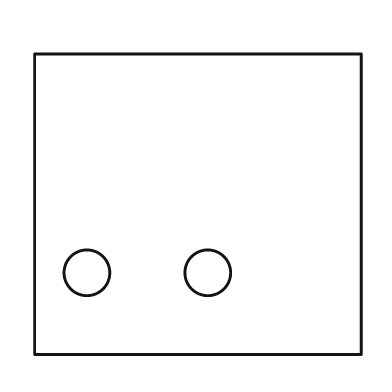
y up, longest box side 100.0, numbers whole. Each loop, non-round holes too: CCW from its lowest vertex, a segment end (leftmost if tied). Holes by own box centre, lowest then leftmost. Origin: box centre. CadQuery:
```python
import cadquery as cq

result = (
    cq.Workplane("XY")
    .moveTo(-50.0, -46.0)
    .lineTo(50.0, -46.0)
    .lineTo(50.0, 46.0)
    .lineTo(-50.0, 46.0)
    .close()
    .moveTo(-34.0, -21.0)
    .circle(7.0)
    .moveTo(3.0, -21.0)
    .circle(7.0)
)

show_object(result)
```